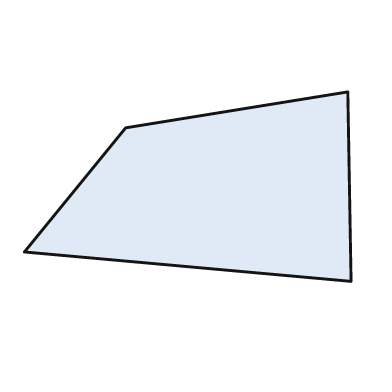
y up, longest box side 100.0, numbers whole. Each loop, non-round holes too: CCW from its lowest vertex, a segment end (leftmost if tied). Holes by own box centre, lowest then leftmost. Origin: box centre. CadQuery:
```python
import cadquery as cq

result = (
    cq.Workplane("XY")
    .moveTo(50.0, -29.0)
    .lineTo(49.0, 29.0)
    .lineTo(-19.0, 18.0)
    .lineTo(-50.0, -20.0)
    .close()
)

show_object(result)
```